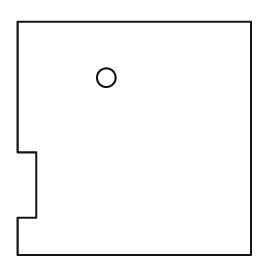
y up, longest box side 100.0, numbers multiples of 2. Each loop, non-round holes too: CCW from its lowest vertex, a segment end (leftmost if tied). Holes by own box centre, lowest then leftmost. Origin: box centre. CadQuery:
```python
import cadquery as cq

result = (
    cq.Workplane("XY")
    .moveTo(-50.0, -50.0)
    .lineTo(50.0, -50.0)
    .lineTo(50.0, 50.0)
    .lineTo(-50.0, 50.0)
    .lineTo(-50.0, -6.0)
    .lineTo(-42.0, -6.0)
    .lineTo(-42.0, -34.0)
    .lineTo(-50.0, -34.0)
    .close()
    .moveTo(-12.0, 26.0)
    .circle(4.0)
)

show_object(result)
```